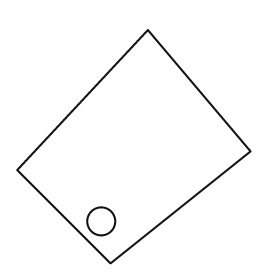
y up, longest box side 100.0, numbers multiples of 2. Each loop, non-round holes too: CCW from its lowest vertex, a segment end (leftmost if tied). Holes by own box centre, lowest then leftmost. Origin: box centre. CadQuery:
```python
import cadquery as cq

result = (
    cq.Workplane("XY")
    .moveTo(-10.0, -50.0)
    .lineTo(50.0, -2.0)
    .lineTo(6.0, 50.0)
    .lineTo(-50.0, -10.0)
    .close()
    .moveTo(-14.0, -32.0)
    .circle(6.0)
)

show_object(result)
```